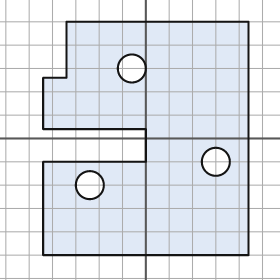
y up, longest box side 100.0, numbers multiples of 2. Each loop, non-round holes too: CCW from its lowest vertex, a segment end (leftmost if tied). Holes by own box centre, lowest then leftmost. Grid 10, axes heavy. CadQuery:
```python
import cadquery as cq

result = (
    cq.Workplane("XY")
    .moveTo(-44.0, -50.0)
    .lineTo(44.0, -50.0)
    .lineTo(44.0, 50.0)
    .lineTo(-34.0, 50.0)
    .lineTo(-34.0, 26.0)
    .lineTo(-44.0, 26.0)
    .lineTo(-44.0, 4.0)
    .lineTo(0.0, 4.0)
    .lineTo(0.0, -10.0)
    .lineTo(-44.0, -10.0)
    .close()
    .moveTo(-24.0, -20.0)
    .circle(6.0)
    .moveTo(30.0, -10.0)
    .circle(6.0)
    .moveTo(-6.0, 30.0)
    .circle(6.0)
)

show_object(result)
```